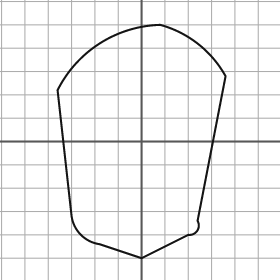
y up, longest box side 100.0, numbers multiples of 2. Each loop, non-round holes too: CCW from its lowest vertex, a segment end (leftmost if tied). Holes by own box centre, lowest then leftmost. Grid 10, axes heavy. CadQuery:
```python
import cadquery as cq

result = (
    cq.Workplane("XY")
    .moveTo(0.0, -50.0)
    .lineTo(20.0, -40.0)
    .threePointArc((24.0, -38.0), (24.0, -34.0))
    .lineTo(36.0, 28.0)
    .threePointArc((24.0, 42.0), (8.0, 50.0))
    .threePointArc((-18.0, 42.0), (-36.0, 22.0))
    .lineTo(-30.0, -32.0)
    .threePointArc((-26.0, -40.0), (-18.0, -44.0))
    .close()
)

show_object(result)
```